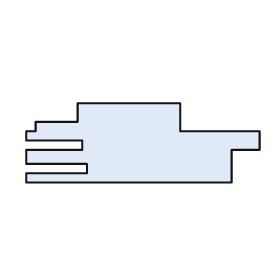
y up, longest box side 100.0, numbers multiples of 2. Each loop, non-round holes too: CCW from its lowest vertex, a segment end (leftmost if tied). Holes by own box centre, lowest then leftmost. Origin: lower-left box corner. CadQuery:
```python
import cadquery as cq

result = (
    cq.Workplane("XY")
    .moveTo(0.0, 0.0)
    .lineTo(88.0, 0.0)
    .lineTo(88.0, 14.0)
    .lineTo(100.0, 14.0)
    .lineTo(100.0, 22.0)
    .lineTo(66.0, 22.0)
    .lineTo(66.0, 34.0)
    .lineTo(22.0, 34.0)
    .lineTo(22.0, 26.0)
    .lineTo(4.0, 26.0)
    .lineTo(4.0, 22.0)
    .lineTo(0.0, 22.0)
    .lineTo(0.0, 18.0)
    .lineTo(24.0, 18.0)
    .lineTo(24.0, 14.0)
    .lineTo(0.0, 14.0)
    .lineTo(0.0, 8.0)
    .lineTo(26.0, 8.0)
    .lineTo(26.0, 4.0)
    .lineTo(0.0, 4.0)
    .close()
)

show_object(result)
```